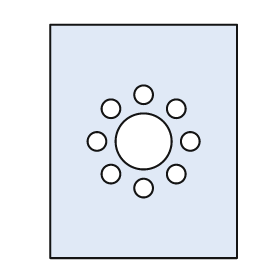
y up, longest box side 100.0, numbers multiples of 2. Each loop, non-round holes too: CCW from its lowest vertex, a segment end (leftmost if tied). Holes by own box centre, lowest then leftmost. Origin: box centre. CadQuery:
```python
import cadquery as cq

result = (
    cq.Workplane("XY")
    .moveTo(-40.0, -50.0)
    .lineTo(40.0, -50.0)
    .lineTo(40.0, 50.0)
    .lineTo(-40.0, 50.0)
    .close()
    .moveTo(0.0, -20.0)
    .circle(4.0)
    .moveTo(-14.0, -14.0)
    .circle(4.0)
    .moveTo(14.0, -14.0)
    .circle(4.0)
    .moveTo(-20.0, 0.0)
    .circle(4.0)
    .moveTo(0.0, 0.0)
    .circle(12.0)
    .moveTo(20.0, 0.0)
    .circle(4.0)
    .moveTo(-14.0, 14.0)
    .circle(4.0)
    .moveTo(14.0, 14.0)
    .circle(4.0)
    .moveTo(0.0, 20.0)
    .circle(4.0)
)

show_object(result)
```